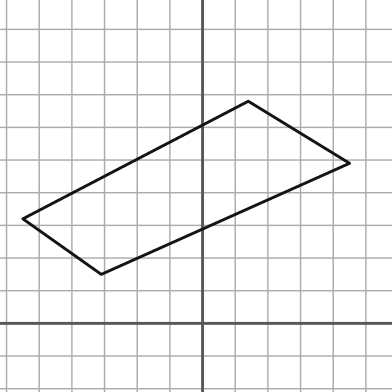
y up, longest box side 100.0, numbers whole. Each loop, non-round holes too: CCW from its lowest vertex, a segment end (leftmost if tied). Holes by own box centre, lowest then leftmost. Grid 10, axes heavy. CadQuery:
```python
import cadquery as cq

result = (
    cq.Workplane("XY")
    .moveTo(-31.0, 15.0)
    .lineTo(45.0, 49.0)
    .lineTo(14.0, 68.0)
    .lineTo(-55.0, 32.0)
    .close()
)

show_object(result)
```